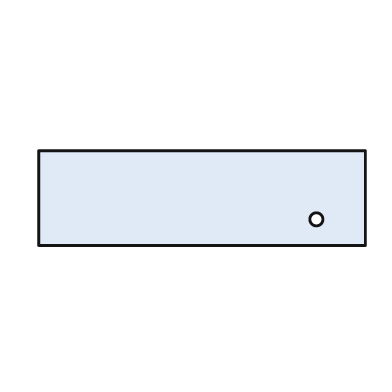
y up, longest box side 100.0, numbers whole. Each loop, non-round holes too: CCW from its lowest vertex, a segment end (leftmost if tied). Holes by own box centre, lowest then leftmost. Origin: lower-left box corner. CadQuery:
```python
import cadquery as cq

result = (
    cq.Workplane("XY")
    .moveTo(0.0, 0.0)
    .lineTo(100.0, 0.0)
    .lineTo(100.0, 29.0)
    .lineTo(0.0, 29.0)
    .close()
    .moveTo(85.0, 8.0)
    .circle(2.0)
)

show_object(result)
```